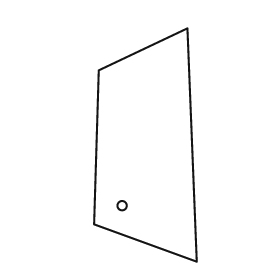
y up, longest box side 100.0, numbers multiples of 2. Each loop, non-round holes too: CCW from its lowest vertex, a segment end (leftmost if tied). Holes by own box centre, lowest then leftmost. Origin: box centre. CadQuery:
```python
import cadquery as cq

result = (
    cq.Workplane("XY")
    .moveTo(22.0, -50.0)
    .lineTo(18.0, 50.0)
    .lineTo(-20.0, 32.0)
    .lineTo(-22.0, -34.0)
    .close()
    .moveTo(-10.0, -26.0)
    .circle(2.0)
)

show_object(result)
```